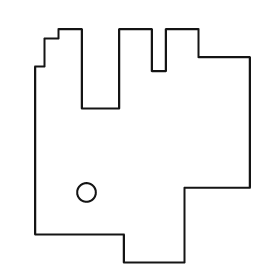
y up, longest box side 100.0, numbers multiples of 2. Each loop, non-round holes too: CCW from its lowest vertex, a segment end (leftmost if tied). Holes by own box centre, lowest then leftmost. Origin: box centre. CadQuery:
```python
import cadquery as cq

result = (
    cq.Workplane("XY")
    .moveTo(-8.0, -50.0)
    .lineTo(18.0, -50.0)
    .lineTo(18.0, -18.0)
    .lineTo(46.0, -18.0)
    .lineTo(46.0, 38.0)
    .lineTo(24.0, 38.0)
    .lineTo(24.0, 50.0)
    .lineTo(10.0, 50.0)
    .lineTo(10.0, 32.0)
    .lineTo(4.0, 32.0)
    .lineTo(4.0, 50.0)
    .lineTo(-10.0, 50.0)
    .lineTo(-10.0, 16.0)
    .lineTo(-26.0, 16.0)
    .lineTo(-26.0, 50.0)
    .lineTo(-36.0, 50.0)
    .lineTo(-36.0, 46.0)
    .lineTo(-42.0, 46.0)
    .lineTo(-42.0, 34.0)
    .lineTo(-46.0, 34.0)
    .lineTo(-46.0, -38.0)
    .lineTo(-8.0, -38.0)
    .close()
    .moveTo(-24.0, -20.0)
    .circle(4.0)
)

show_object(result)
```